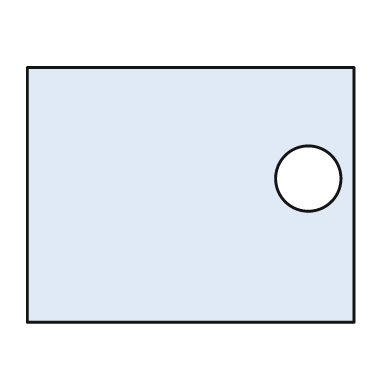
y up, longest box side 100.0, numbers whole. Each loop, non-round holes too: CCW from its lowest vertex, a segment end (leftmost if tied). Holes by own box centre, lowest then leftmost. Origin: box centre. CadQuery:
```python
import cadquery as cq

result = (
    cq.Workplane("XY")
    .moveTo(-50.0, -39.0)
    .lineTo(50.0, -39.0)
    .lineTo(50.0, 39.0)
    .lineTo(-50.0, 39.0)
    .close()
    .moveTo(36.0, 5.0)
    .circle(10.0)
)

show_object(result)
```